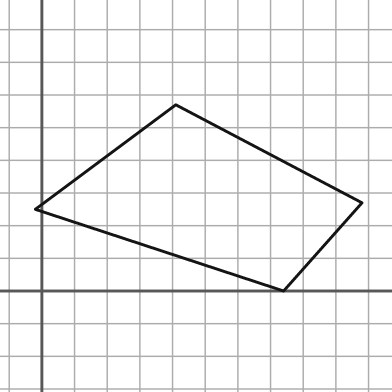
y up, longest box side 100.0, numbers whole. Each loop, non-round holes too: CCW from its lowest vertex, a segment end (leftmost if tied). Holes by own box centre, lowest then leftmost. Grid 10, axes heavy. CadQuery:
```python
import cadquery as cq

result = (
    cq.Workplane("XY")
    .moveTo(74.0, 0.0)
    .lineTo(98.0, 27.0)
    .lineTo(41.0, 57.0)
    .lineTo(-2.0, 25.0)
    .close()
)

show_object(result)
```